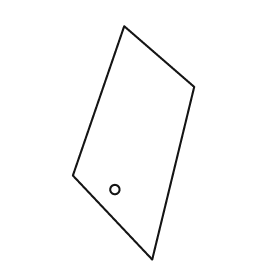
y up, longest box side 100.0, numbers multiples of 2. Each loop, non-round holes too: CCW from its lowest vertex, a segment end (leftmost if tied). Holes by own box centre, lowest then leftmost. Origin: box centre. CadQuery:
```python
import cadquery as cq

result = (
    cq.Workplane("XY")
    .moveTo(8.0, -50.0)
    .lineTo(26.0, 24.0)
    .lineTo(-4.0, 50.0)
    .lineTo(-26.0, -14.0)
    .close()
    .moveTo(-8.0, -20.0)
    .circle(2.0)
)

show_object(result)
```